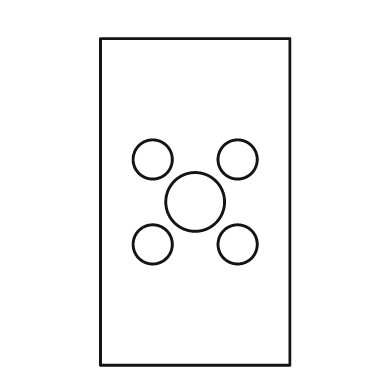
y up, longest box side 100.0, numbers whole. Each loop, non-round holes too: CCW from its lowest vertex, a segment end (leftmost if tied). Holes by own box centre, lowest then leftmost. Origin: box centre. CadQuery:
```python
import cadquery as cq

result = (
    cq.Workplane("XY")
    .moveTo(-29.0, -50.0)
    .lineTo(29.0, -50.0)
    .lineTo(29.0, 50.0)
    .lineTo(-29.0, 50.0)
    .close()
    .moveTo(-13.0, -13.0)
    .circle(6.0)
    .moveTo(13.0, -13.0)
    .circle(6.0)
    .moveTo(0.0, 0.0)
    .circle(9.0)
    .moveTo(-13.0, 13.0)
    .circle(6.0)
    .moveTo(13.0, 13.0)
    .circle(6.0)
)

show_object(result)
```